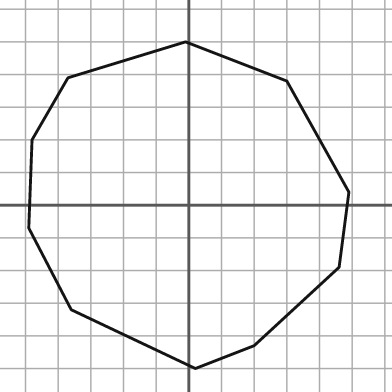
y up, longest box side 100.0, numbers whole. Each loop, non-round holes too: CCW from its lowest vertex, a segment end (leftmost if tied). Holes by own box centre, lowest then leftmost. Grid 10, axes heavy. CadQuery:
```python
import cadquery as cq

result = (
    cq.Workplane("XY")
    .moveTo(2.0, -50.0)
    .lineTo(20.0, -43.0)
    .lineTo(46.0, -19.0)
    .lineTo(49.0, 4.0)
    .lineTo(30.0, 38.0)
    .lineTo(-1.0, 50.0)
    .lineTo(-37.0, 39.0)
    .lineTo(-48.0, 20.0)
    .lineTo(-49.0, -7.0)
    .lineTo(-36.0, -32.0)
    .close()
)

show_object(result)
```